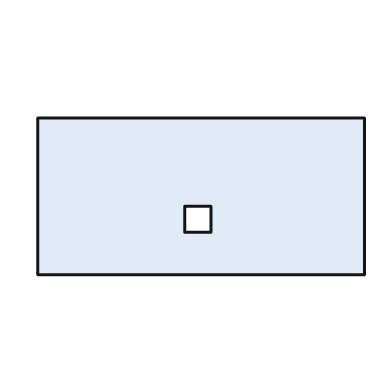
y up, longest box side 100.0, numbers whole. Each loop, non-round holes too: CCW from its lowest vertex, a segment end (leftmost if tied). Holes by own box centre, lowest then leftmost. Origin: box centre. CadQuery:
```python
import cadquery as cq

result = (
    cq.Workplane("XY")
    .moveTo(-50.0, -24.0)
    .lineTo(50.0, -24.0)
    .lineTo(50.0, 24.0)
    .lineTo(-50.0, 24.0)
    .close()
    .moveTo(-5.0, -11.0)
    .lineTo(3.0, -11.0)
    .lineTo(3.0, -3.0)
    .lineTo(-5.0, -3.0)
    .close()
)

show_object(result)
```